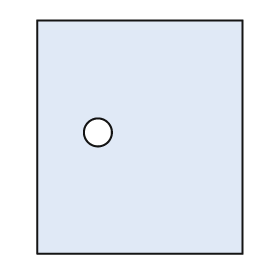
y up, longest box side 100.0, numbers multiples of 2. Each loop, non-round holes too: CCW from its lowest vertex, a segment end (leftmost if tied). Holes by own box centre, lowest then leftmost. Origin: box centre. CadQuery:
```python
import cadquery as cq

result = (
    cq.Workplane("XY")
    .moveTo(-44.0, -50.0)
    .lineTo(44.0, -50.0)
    .lineTo(44.0, 50.0)
    .lineTo(-44.0, 50.0)
    .close()
    .moveTo(-18.0, 2.0)
    .circle(6.0)
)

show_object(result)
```